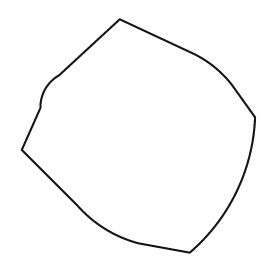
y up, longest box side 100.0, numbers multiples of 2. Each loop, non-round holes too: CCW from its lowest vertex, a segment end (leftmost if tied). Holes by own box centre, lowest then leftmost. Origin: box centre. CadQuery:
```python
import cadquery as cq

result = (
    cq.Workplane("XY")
    .moveTo(22.0, -50.0)
    .threePointArc((42.0, -24.0), (50.0, 8.0))
    .lineTo(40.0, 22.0)
    .threePointArc((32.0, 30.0), (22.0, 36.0))
    .lineTo(-8.0, 50.0)
    .lineTo(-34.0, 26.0)
    .threePointArc((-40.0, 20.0), (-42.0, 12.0))
    .lineTo(-50.0, -6.0)
    .lineTo(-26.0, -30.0)
    .threePointArc((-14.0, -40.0), (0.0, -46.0))
    .close()
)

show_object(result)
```